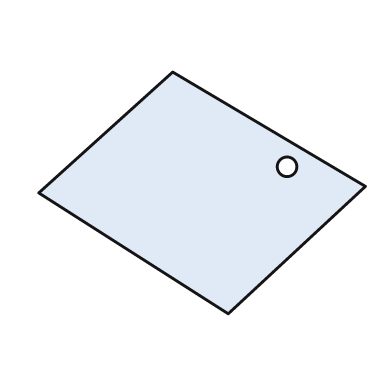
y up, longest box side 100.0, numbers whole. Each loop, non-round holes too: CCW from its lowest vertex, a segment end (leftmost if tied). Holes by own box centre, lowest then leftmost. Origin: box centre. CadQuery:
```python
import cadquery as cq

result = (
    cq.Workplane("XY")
    .moveTo(8.0, -37.0)
    .lineTo(50.0, 2.0)
    .lineTo(-9.0, 37.0)
    .lineTo(-50.0, 0.0)
    .close()
    .moveTo(26.0, 8.0)
    .circle(3.0)
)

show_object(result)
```